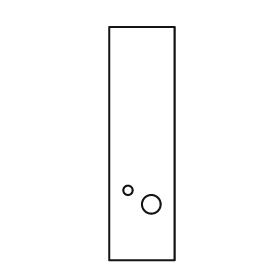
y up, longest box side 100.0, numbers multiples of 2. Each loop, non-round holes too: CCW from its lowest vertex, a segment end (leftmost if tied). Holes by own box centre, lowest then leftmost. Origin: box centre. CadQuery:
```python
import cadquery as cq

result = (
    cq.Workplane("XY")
    .moveTo(-14.0, -50.0)
    .lineTo(14.0, -50.0)
    .lineTo(14.0, 50.0)
    .lineTo(-14.0, 50.0)
    .close()
    .moveTo(4.0, -26.0)
    .circle(4.0)
    .moveTo(-6.0, -20.0)
    .circle(2.0)
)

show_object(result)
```